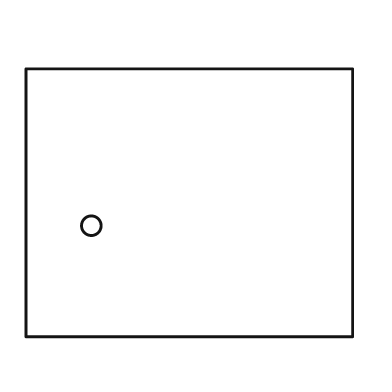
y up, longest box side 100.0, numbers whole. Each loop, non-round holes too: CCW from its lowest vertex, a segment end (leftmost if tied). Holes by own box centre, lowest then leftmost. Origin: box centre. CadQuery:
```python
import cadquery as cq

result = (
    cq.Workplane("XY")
    .moveTo(-50.0, -41.0)
    .lineTo(50.0, -41.0)
    .lineTo(50.0, 41.0)
    .lineTo(-50.0, 41.0)
    .close()
    .moveTo(-30.0, -7.0)
    .circle(3.0)
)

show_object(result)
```